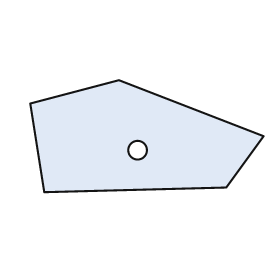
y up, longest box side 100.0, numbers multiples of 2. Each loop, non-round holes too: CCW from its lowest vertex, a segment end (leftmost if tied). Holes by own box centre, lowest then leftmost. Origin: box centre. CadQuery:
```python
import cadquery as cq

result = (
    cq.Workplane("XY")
    .moveTo(-44.0, -24.0)
    .lineTo(34.0, -22.0)
    .lineTo(50.0, 0.0)
    .lineTo(-12.0, 24.0)
    .lineTo(-50.0, 14.0)
    .close()
    .moveTo(-4.0, -6.0)
    .circle(4.0)
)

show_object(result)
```